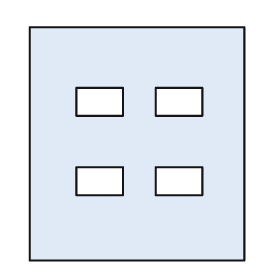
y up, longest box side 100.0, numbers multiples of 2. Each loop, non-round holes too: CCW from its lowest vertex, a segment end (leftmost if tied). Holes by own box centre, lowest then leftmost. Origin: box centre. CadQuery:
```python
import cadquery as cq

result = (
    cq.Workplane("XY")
    .moveTo(-46.0, -50.0)
    .lineTo(46.0, -50.0)
    .lineTo(46.0, 50.0)
    .lineTo(-46.0, 50.0)
    .close()
    .moveTo(-26.0, -22.0)
    .lineTo(-6.0, -22.0)
    .lineTo(-6.0, -10.0)
    .lineTo(-26.0, -10.0)
    .close()
    .moveTo(8.0, -22.0)
    .lineTo(28.0, -22.0)
    .lineTo(28.0, -10.0)
    .lineTo(8.0, -10.0)
    .close()
    .moveTo(-26.0, 12.0)
    .lineTo(-6.0, 12.0)
    .lineTo(-6.0, 24.0)
    .lineTo(-26.0, 24.0)
    .close()
    .moveTo(8.0, 12.0)
    .lineTo(28.0, 12.0)
    .lineTo(28.0, 24.0)
    .lineTo(8.0, 24.0)
    .close()
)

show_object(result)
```